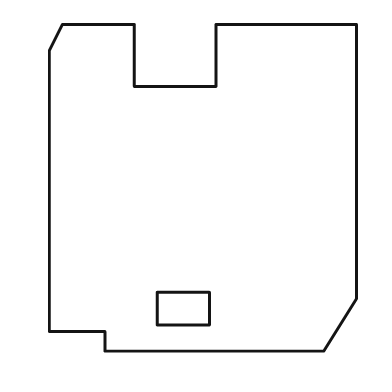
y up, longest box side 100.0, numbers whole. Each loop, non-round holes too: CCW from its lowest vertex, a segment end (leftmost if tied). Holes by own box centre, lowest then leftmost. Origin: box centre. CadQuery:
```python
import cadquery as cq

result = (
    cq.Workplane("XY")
    .moveTo(-30.0, -50.0)
    .lineTo(37.0, -50.0)
    .lineTo(47.0, -34.0)
    .lineTo(47.0, 50.0)
    .lineTo(4.0, 50.0)
    .lineTo(4.0, 31.0)
    .lineTo(-21.0, 31.0)
    .lineTo(-21.0, 50.0)
    .lineTo(-43.0, 50.0)
    .lineTo(-47.0, 42.0)
    .lineTo(-47.0, -44.0)
    .lineTo(-30.0, -44.0)
    .close()
    .moveTo(-14.0, -42.0)
    .lineTo(2.0, -42.0)
    .lineTo(2.0, -32.0)
    .lineTo(-14.0, -32.0)
    .close()
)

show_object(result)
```